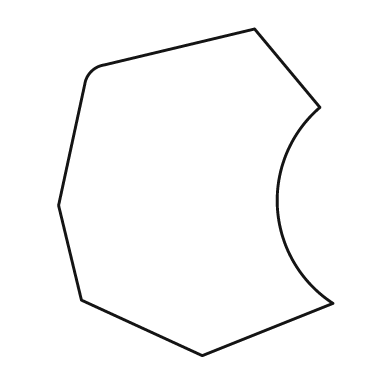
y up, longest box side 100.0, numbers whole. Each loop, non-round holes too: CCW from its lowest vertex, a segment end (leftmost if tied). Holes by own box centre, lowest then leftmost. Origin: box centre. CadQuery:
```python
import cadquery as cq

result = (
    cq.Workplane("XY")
    .moveTo(2.0, -50.0)
    .lineTo(42.0, -34.0)
    .threePointArc((25.0, -5.0), (38.0, 26.0))
    .lineTo(18.0, 50.0)
    .lineTo(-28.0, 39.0)
    .threePointArc((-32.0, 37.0), (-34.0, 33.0))
    .lineTo(-42.0, -4.0)
    .lineTo(-35.0, -33.0)
    .close()
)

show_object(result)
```